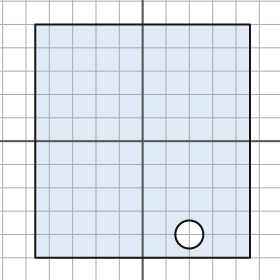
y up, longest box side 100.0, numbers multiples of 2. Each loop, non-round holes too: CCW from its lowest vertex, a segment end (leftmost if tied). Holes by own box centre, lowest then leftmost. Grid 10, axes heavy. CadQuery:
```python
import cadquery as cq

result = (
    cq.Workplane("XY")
    .moveTo(-46.0, -50.0)
    .lineTo(46.0, -50.0)
    .lineTo(46.0, 50.0)
    .lineTo(-46.0, 50.0)
    .close()
    .moveTo(20.0, -40.0)
    .circle(6.0)
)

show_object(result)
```